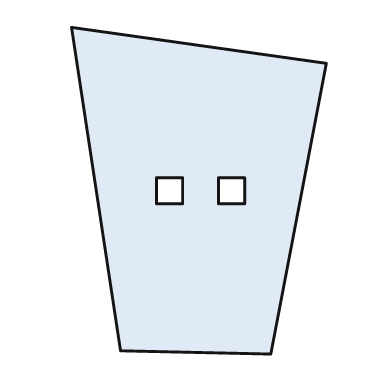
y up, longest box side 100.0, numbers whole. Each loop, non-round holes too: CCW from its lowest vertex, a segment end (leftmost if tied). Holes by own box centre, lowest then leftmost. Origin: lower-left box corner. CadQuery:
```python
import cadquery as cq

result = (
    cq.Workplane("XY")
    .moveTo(61.0, 0.0)
    .lineTo(78.0, 89.0)
    .lineTo(0.0, 100.0)
    .lineTo(15.0, 1.0)
    .close()
    .moveTo(26.0, 46.0)
    .lineTo(34.0, 46.0)
    .lineTo(34.0, 54.0)
    .lineTo(26.0, 54.0)
    .close()
    .moveTo(45.0, 46.0)
    .lineTo(53.0, 46.0)
    .lineTo(53.0, 54.0)
    .lineTo(45.0, 54.0)
    .close()
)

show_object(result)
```